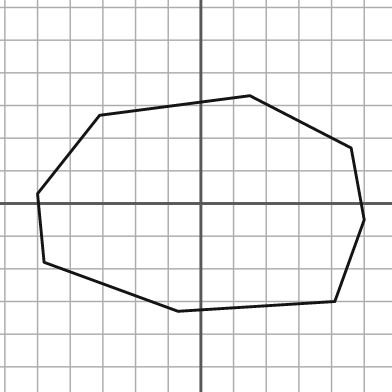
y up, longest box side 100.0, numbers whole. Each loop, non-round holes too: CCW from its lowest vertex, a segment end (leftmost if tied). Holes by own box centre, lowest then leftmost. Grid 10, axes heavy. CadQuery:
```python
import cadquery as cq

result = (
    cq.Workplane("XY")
    .moveTo(-7.0, -33.0)
    .lineTo(41.0, -30.0)
    .lineTo(50.0, -5.0)
    .lineTo(46.0, 17.0)
    .lineTo(15.0, 33.0)
    .lineTo(-31.0, 27.0)
    .lineTo(-50.0, 3.0)
    .lineTo(-48.0, -18.0)
    .close()
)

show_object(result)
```